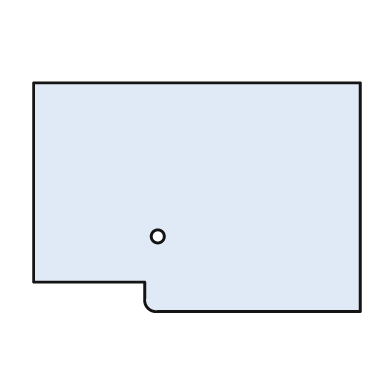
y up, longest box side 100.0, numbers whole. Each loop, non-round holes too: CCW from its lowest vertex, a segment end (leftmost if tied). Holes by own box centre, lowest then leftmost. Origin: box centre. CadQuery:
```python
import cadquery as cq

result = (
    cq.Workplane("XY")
    .moveTo(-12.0, -35.0)
    .lineTo(50.0, -35.0)
    .lineTo(50.0, 35.0)
    .lineTo(-50.0, 35.0)
    .lineTo(-50.0, -26.0)
    .lineTo(-16.0, -26.0)
    .lineTo(-16.0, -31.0)
    .threePointArc((-15.0, -34.0), (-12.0, -35.0))
    .close()
    .moveTo(-12.0, -12.0)
    .circle(2.0)
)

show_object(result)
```